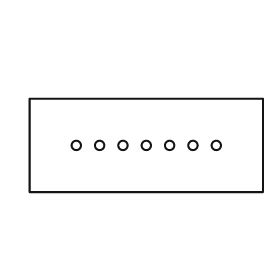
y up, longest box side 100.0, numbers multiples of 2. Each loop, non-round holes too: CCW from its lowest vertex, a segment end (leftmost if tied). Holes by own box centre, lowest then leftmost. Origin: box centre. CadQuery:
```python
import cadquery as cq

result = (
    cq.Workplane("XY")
    .moveTo(-50.0, -20.0)
    .lineTo(50.0, -20.0)
    .lineTo(50.0, 20.0)
    .lineTo(-50.0, 20.0)
    .close()
    .moveTo(-30.0, 0.0)
    .circle(2.0)
    .moveTo(-20.0, 0.0)
    .circle(2.0)
    .moveTo(-10.0, 0.0)
    .circle(2.0)
    .moveTo(0.0, 0.0)
    .circle(2.0)
    .moveTo(10.0, 0.0)
    .circle(2.0)
    .moveTo(20.0, 0.0)
    .circle(2.0)
    .moveTo(30.0, 0.0)
    .circle(2.0)
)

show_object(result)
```